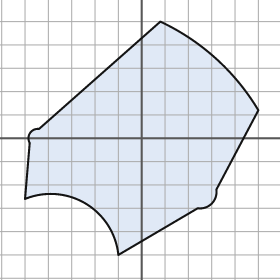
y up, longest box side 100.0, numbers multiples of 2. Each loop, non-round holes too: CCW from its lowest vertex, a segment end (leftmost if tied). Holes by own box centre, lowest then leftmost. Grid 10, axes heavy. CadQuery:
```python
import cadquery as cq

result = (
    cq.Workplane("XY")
    .moveTo(-10.0, -50.0)
    .lineTo(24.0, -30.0)
    .threePointArc((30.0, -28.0), (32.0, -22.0))
    .lineTo(50.0, 12.0)
    .threePointArc((32.0, 34.0), (8.0, 50.0))
    .lineTo(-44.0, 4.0)
    .threePointArc((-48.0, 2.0), (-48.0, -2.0))
    .lineTo(-50.0, -26.0)
    .threePointArc((-24.0, -28.0), (-10.0, -50.0))
    .close()
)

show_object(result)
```